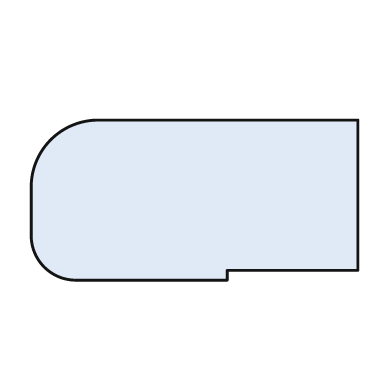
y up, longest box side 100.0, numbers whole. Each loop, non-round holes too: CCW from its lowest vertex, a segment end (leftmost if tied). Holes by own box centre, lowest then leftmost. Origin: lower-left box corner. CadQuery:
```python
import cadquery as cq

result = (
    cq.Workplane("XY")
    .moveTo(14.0, 0.0)
    .lineTo(60.0, 0.0)
    .lineTo(60.0, 3.0)
    .lineTo(100.0, 3.0)
    .lineTo(100.0, 49.0)
    .lineTo(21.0, 49.0)
    .threePointArc((6.0, 43.0), (0.0, 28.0))
    .lineTo(0.0, 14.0)
    .threePointArc((4.0, 4.0), (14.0, 0.0))
    .close()
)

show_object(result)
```